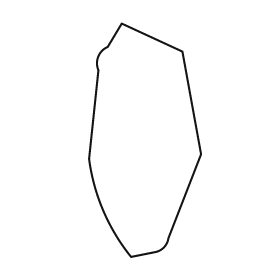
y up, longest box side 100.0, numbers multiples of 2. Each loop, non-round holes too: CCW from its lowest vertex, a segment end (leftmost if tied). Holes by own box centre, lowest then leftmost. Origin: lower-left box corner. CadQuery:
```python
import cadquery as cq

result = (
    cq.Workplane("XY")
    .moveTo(18.0, 0.0)
    .lineTo(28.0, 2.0)
    .threePointArc((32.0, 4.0), (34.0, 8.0))
    .lineTo(48.0, 44.0)
    .lineTo(40.0, 88.0)
    .lineTo(14.0, 100.0)
    .lineTo(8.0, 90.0)
    .threePointArc((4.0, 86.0), (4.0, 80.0))
    .lineTo(0.0, 42.0)
    .threePointArc((6.0, 20.0), (18.0, 0.0))
    .close()
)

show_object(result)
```